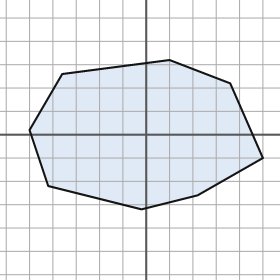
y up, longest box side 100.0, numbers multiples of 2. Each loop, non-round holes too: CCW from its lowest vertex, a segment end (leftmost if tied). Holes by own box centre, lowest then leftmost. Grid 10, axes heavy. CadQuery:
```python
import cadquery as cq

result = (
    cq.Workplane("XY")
    .moveTo(-2.0, -32.0)
    .lineTo(22.0, -26.0)
    .lineTo(50.0, -10.0)
    .lineTo(36.0, 22.0)
    .lineTo(10.0, 32.0)
    .lineTo(-36.0, 26.0)
    .lineTo(-50.0, 2.0)
    .lineTo(-42.0, -22.0)
    .close()
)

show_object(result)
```